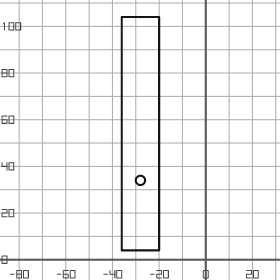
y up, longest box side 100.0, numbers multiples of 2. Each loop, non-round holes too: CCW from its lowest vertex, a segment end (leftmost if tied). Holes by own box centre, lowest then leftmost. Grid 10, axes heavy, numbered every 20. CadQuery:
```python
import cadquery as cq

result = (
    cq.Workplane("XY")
    .moveTo(-36.0, 4.0)
    .lineTo(-20.0, 4.0)
    .lineTo(-20.0, 104.0)
    .lineTo(-36.0, 104.0)
    .close()
    .moveTo(-28.0, 34.0)
    .circle(2.0)
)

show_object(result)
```